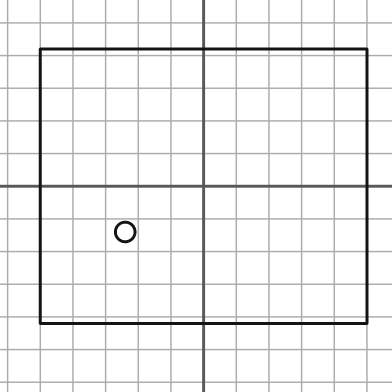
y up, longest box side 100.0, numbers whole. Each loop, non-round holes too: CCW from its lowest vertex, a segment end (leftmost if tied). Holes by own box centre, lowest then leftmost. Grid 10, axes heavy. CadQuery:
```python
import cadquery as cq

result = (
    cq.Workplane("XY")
    .moveTo(-50.0, -42.0)
    .lineTo(50.0, -42.0)
    .lineTo(50.0, 42.0)
    .lineTo(-50.0, 42.0)
    .close()
    .moveTo(-24.0, -14.0)
    .circle(3.0)
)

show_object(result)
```